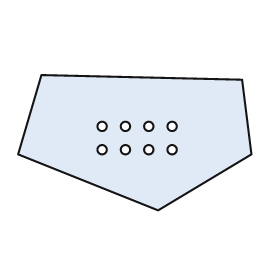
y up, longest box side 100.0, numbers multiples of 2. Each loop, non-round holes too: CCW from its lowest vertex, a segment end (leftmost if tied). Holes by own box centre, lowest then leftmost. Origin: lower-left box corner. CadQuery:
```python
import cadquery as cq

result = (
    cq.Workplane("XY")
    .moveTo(60.0, 0.0)
    .lineTo(100.0, 24.0)
    .lineTo(96.0, 56.0)
    .lineTo(10.0, 58.0)
    .lineTo(0.0, 24.0)
    .close()
    .moveTo(36.0, 26.0)
    .circle(2.0)
    .moveTo(46.0, 26.0)
    .circle(2.0)
    .moveTo(56.0, 26.0)
    .circle(2.0)
    .moveTo(66.0, 26.0)
    .circle(2.0)
    .moveTo(36.0, 36.0)
    .circle(2.0)
    .moveTo(46.0, 36.0)
    .circle(2.0)
    .moveTo(56.0, 36.0)
    .circle(2.0)
    .moveTo(66.0, 36.0)
    .circle(2.0)
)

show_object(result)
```